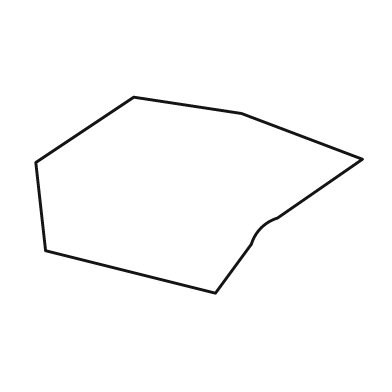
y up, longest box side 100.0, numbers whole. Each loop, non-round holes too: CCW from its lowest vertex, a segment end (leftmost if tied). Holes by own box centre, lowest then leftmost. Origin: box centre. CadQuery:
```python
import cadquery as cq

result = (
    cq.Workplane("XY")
    .moveTo(5.0, -30.0)
    .lineTo(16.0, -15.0)
    .threePointArc((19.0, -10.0), (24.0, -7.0))
    .lineTo(50.0, 11.0)
    .lineTo(13.0, 25.0)
    .lineTo(-20.0, 30.0)
    .lineTo(-50.0, 10.0)
    .lineTo(-47.0, -17.0)
    .close()
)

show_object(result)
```